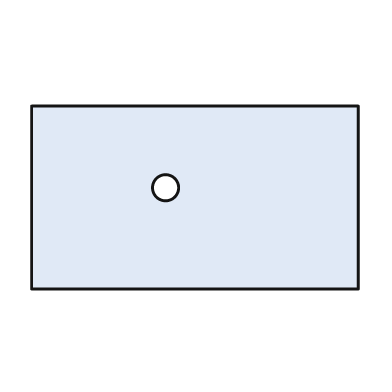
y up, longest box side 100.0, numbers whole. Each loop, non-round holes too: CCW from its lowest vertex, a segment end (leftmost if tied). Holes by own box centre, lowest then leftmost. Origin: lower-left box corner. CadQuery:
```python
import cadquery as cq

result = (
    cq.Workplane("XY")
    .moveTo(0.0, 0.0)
    .lineTo(100.0, 0.0)
    .lineTo(100.0, 56.0)
    .lineTo(0.0, 56.0)
    .close()
    .moveTo(41.0, 31.0)
    .circle(4.0)
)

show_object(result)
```